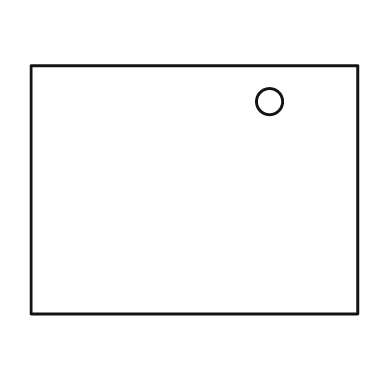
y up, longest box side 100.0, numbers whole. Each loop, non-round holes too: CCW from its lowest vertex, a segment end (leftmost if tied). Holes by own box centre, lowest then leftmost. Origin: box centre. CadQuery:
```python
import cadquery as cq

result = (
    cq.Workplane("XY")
    .moveTo(-50.0, -38.0)
    .lineTo(50.0, -38.0)
    .lineTo(50.0, 38.0)
    .lineTo(-50.0, 38.0)
    .close()
    .moveTo(23.0, 27.0)
    .circle(4.0)
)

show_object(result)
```